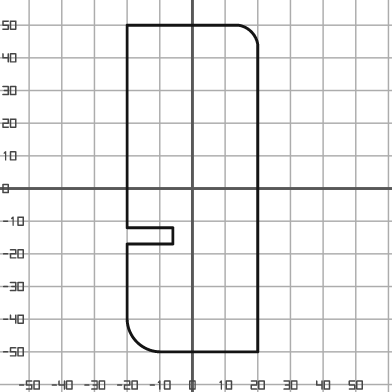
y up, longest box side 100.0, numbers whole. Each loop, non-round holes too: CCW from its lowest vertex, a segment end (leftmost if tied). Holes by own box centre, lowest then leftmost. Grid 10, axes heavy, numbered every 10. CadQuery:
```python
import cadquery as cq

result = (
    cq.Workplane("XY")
    .moveTo(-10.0, -50.0)
    .lineTo(20.0, -50.0)
    .lineTo(20.0, 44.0)
    .threePointArc((18.0, 48.0), (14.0, 50.0))
    .lineTo(-20.0, 50.0)
    .lineTo(-20.0, -12.0)
    .lineTo(-6.0, -12.0)
    .lineTo(-6.0, -17.0)
    .lineTo(-20.0, -17.0)
    .lineTo(-20.0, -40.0)
    .threePointArc((-17.0, -47.0), (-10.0, -50.0))
    .close()
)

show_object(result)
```